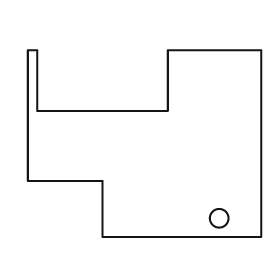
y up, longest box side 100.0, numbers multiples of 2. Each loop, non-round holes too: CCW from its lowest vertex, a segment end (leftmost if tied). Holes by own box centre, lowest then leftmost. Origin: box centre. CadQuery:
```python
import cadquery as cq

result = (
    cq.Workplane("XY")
    .moveTo(-18.0, -40.0)
    .lineTo(50.0, -40.0)
    .lineTo(50.0, 40.0)
    .lineTo(10.0, 40.0)
    .lineTo(10.0, 14.0)
    .lineTo(-46.0, 14.0)
    .lineTo(-46.0, 40.0)
    .lineTo(-50.0, 40.0)
    .lineTo(-50.0, -16.0)
    .lineTo(-18.0, -16.0)
    .close()
    .moveTo(32.0, -32.0)
    .circle(4.0)
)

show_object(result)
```